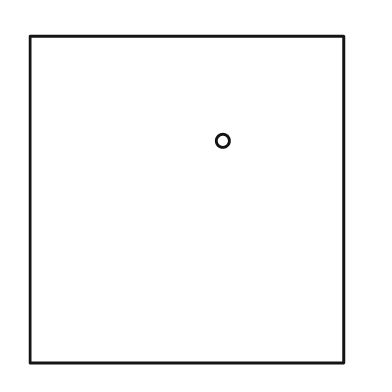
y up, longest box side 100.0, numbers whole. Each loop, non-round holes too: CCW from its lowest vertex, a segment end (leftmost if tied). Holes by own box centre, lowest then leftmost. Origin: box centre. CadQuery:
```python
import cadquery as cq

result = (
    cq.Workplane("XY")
    .moveTo(-48.0, -50.0)
    .lineTo(48.0, -50.0)
    .lineTo(48.0, 50.0)
    .lineTo(-48.0, 50.0)
    .close()
    .moveTo(11.0, 18.0)
    .circle(2.0)
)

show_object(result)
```